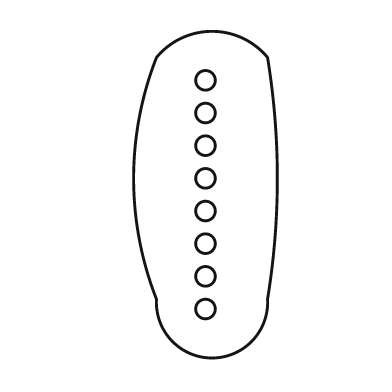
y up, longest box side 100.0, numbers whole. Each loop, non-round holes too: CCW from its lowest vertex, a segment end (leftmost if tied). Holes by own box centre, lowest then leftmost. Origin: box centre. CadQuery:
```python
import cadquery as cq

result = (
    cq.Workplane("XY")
    .moveTo(-15.0, -32.0)
    .threePointArc((2.0, -50.0), (19.0, -32.0))
    .threePointArc((22.0, 5.0), (19.0, 42.0))
    .threePointArc((2.0, 50.0), (-15.0, 42.0))
    .threePointArc((-22.0, 5.0), (-15.0, -32.0))
    .close()
    .moveTo(0.0, -35.0)
    .circle(3.0)
    .moveTo(0.0, -25.0)
    .circle(3.0)
    .moveTo(0.0, -15.0)
    .circle(3.0)
    .moveTo(0.0, -5.0)
    .circle(3.0)
    .moveTo(0.0, 5.0)
    .circle(3.0)
    .moveTo(0.0, 15.0)
    .circle(3.0)
    .moveTo(0.0, 25.0)
    .circle(3.0)
    .moveTo(0.0, 35.0)
    .circle(3.0)
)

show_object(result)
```